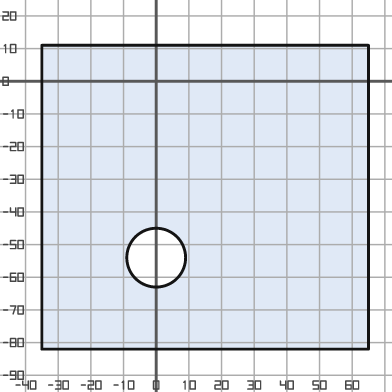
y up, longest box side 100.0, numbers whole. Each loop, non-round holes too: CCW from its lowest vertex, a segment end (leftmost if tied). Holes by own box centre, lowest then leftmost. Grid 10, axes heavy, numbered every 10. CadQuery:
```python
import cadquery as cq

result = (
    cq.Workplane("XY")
    .moveTo(-35.0, -82.0)
    .lineTo(65.0, -82.0)
    .lineTo(65.0, 11.0)
    .lineTo(-35.0, 11.0)
    .close()
    .moveTo(0.0, -54.0)
    .circle(9.0)
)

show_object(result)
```